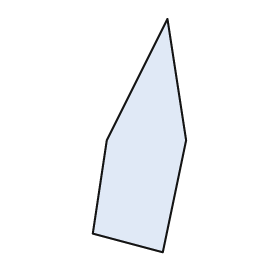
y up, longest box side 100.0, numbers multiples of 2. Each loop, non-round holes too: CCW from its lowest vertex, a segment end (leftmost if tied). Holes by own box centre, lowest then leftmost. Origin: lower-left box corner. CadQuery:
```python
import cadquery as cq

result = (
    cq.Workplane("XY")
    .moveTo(30.0, 0.0)
    .lineTo(40.0, 48.0)
    .lineTo(32.0, 100.0)
    .lineTo(6.0, 48.0)
    .lineTo(0.0, 8.0)
    .close()
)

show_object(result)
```